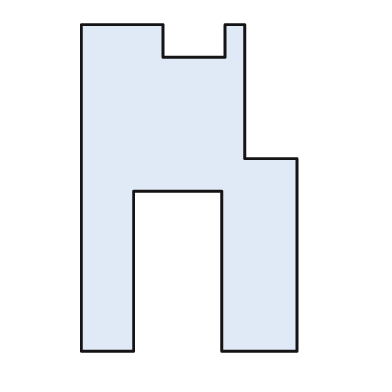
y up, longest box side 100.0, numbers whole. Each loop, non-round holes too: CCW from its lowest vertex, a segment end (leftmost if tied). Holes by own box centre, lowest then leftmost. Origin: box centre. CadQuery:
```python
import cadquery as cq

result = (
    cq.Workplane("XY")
    .moveTo(-33.0, -50.0)
    .lineTo(-17.0, -50.0)
    .lineTo(-17.0, -1.0)
    .lineTo(10.0, -1.0)
    .lineTo(10.0, -50.0)
    .lineTo(33.0, -50.0)
    .lineTo(33.0, 9.0)
    .lineTo(17.0, 9.0)
    .lineTo(17.0, 50.0)
    .lineTo(11.0, 50.0)
    .lineTo(11.0, 40.0)
    .lineTo(-8.0, 40.0)
    .lineTo(-8.0, 50.0)
    .lineTo(-33.0, 50.0)
    .close()
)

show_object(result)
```